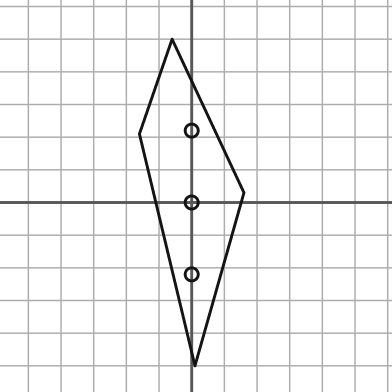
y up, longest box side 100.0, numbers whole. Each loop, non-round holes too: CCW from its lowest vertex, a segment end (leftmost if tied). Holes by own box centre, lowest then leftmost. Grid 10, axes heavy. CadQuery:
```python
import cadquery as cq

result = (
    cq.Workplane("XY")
    .moveTo(1.0, -50.0)
    .lineTo(16.0, 3.0)
    .lineTo(-6.0, 50.0)
    .lineTo(-16.0, 21.0)
    .close()
    .moveTo(0.0, -22.0)
    .circle(2.0)
    .moveTo(0.0, 0.0)
    .circle(2.0)
    .moveTo(0.0, 22.0)
    .circle(2.0)
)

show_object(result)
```